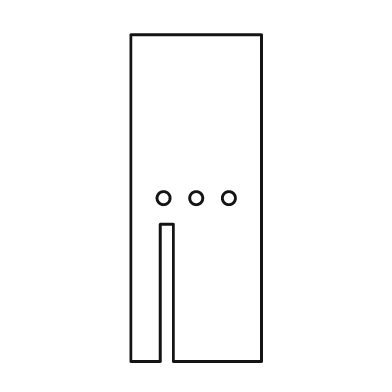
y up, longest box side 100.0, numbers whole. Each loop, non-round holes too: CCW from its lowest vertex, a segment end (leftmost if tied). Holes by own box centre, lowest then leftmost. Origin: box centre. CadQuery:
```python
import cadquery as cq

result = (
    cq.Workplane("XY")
    .moveTo(-20.0, -50.0)
    .lineTo(-11.0, -50.0)
    .lineTo(-11.0, -8.0)
    .lineTo(-7.0, -8.0)
    .lineTo(-7.0, -50.0)
    .lineTo(20.0, -50.0)
    .lineTo(20.0, 50.0)
    .lineTo(-20.0, 50.0)
    .close()
    .moveTo(-10.0, 0.0)
    .circle(2.0)
    .moveTo(0.0, 0.0)
    .circle(2.0)
    .moveTo(10.0, 0.0)
    .circle(2.0)
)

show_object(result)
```